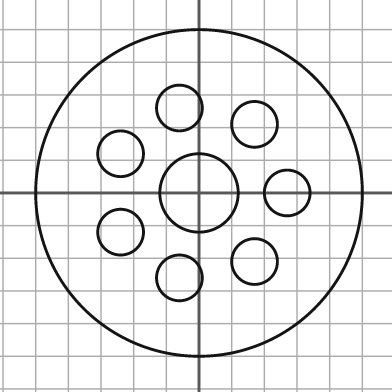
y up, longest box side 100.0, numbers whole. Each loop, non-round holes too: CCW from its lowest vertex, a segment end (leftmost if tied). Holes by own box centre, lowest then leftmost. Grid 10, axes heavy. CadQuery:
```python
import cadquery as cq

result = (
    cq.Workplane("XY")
    .moveTo(0.0, 0.0)
    .circle(50.0)
    .moveTo(-6.0, -26.0)
    .circle(7.0)
    .moveTo(17.0, -21.0)
    .circle(7.0)
    .moveTo(-24.0, -12.0)
    .circle(7.0)
    .moveTo(0.0, 0.0)
    .circle(12.0)
    .moveTo(27.0, 0.0)
    .circle(7.0)
    .moveTo(-24.0, 12.0)
    .circle(7.0)
    .moveTo(17.0, 21.0)
    .circle(7.0)
    .moveTo(-6.0, 26.0)
    .circle(7.0)
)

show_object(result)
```